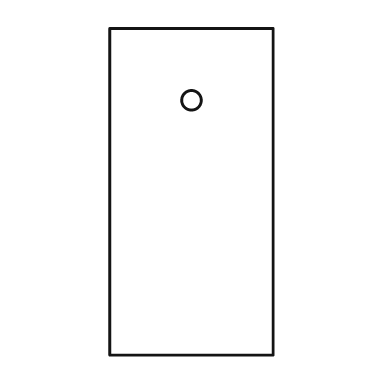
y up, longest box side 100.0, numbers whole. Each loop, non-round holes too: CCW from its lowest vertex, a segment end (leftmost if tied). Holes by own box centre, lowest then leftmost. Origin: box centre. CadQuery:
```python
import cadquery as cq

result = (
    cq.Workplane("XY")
    .moveTo(-25.0, -50.0)
    .lineTo(25.0, -50.0)
    .lineTo(25.0, 50.0)
    .lineTo(-25.0, 50.0)
    .close()
    .moveTo(0.0, 28.0)
    .circle(3.0)
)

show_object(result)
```